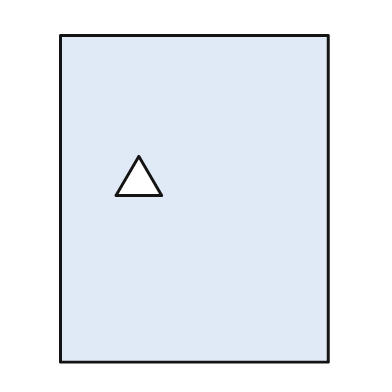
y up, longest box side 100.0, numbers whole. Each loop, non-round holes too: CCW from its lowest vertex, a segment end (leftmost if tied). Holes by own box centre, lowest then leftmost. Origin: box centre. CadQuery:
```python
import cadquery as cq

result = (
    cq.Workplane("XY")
    .moveTo(-41.0, -50.0)
    .lineTo(41.0, -50.0)
    .lineTo(41.0, 50.0)
    .lineTo(-41.0, 50.0)
    .close()
    .moveTo(-24.0, 1.0)
    .lineTo(-10.0, 1.0)
    .lineTo(-17.0, 13.0)
    .close()
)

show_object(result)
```